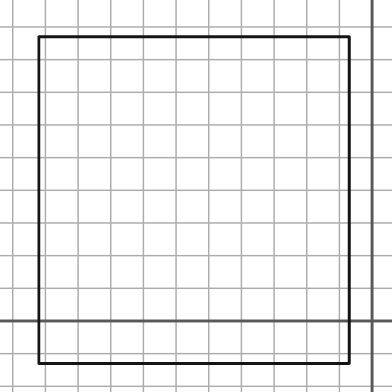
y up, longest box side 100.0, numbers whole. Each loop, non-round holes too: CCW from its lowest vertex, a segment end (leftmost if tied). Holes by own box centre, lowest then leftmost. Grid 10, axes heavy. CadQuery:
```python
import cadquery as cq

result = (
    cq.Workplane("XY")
    .moveTo(-102.0, -13.0)
    .lineTo(-7.0, -13.0)
    .lineTo(-7.0, 87.0)
    .lineTo(-102.0, 87.0)
    .close()
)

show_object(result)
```